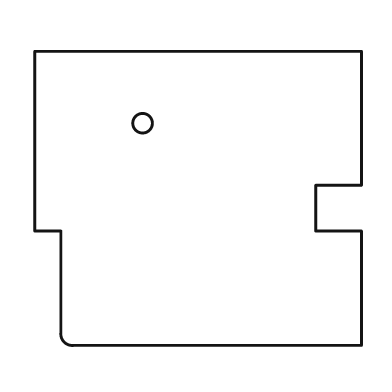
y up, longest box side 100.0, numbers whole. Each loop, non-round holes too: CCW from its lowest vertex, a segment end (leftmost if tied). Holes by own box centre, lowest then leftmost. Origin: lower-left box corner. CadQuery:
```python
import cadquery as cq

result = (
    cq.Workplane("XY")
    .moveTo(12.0, 0.0)
    .lineTo(100.0, 0.0)
    .lineTo(100.0, 35.0)
    .lineTo(86.0, 35.0)
    .lineTo(86.0, 49.0)
    .lineTo(100.0, 49.0)
    .lineTo(100.0, 90.0)
    .lineTo(0.0, 90.0)
    .lineTo(0.0, 35.0)
    .lineTo(8.0, 35.0)
    .lineTo(8.0, 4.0)
    .threePointArc((9.0, 1.0), (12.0, 0.0))
    .close()
    .moveTo(33.0, 68.0)
    .circle(3.0)
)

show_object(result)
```